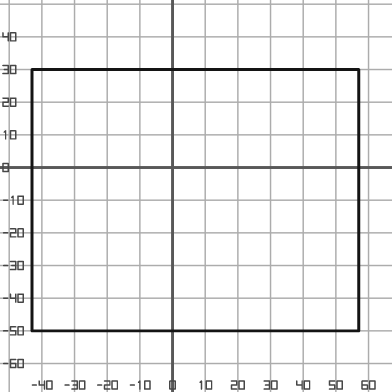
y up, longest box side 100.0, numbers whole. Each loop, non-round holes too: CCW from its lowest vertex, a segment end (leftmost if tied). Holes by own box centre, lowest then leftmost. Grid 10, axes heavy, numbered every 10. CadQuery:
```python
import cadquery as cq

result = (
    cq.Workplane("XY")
    .moveTo(-43.0, -50.0)
    .lineTo(57.0, -50.0)
    .lineTo(57.0, 30.0)
    .lineTo(-43.0, 30.0)
    .close()
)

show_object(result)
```